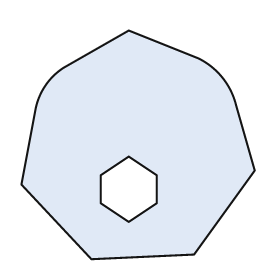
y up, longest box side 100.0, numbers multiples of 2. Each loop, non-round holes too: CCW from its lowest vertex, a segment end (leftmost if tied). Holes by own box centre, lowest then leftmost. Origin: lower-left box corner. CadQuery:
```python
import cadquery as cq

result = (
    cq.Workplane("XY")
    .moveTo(30.0, 0.0)
    .lineTo(74.0, 2.0)
    .lineTo(100.0, 38.0)
    .lineTo(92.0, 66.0)
    .threePointArc((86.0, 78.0), (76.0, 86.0))
    .lineTo(46.0, 98.0)
    .lineTo(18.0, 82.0)
    .threePointArc((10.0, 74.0), (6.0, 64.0))
    .lineTo(0.0, 32.0)
    .close()
    .moveTo(46.0, 16.0)
    .lineTo(58.0, 24.0)
    .lineTo(58.0, 36.0)
    .lineTo(46.0, 44.0)
    .lineTo(34.0, 36.0)
    .lineTo(34.0, 24.0)
    .close()
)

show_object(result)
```